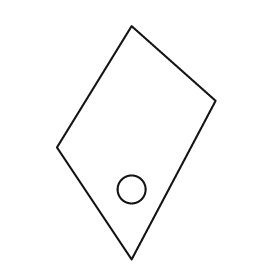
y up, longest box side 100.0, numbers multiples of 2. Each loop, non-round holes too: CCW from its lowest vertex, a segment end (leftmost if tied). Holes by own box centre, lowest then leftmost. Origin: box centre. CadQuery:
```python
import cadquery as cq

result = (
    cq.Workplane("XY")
    .moveTo(-2.0, -50.0)
    .lineTo(34.0, 18.0)
    .lineTo(-2.0, 50.0)
    .lineTo(-34.0, -2.0)
    .close()
    .moveTo(-2.0, -20.0)
    .circle(6.0)
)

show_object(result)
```